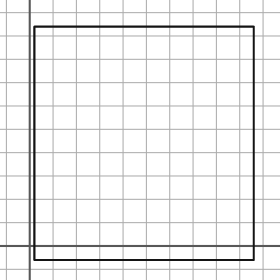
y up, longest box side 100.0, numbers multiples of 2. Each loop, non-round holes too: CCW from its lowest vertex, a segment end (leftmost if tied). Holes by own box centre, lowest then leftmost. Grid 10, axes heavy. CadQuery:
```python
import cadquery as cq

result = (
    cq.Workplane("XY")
    .moveTo(2.0, -6.0)
    .lineTo(96.0, -6.0)
    .lineTo(96.0, 94.0)
    .lineTo(2.0, 94.0)
    .close()
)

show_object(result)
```